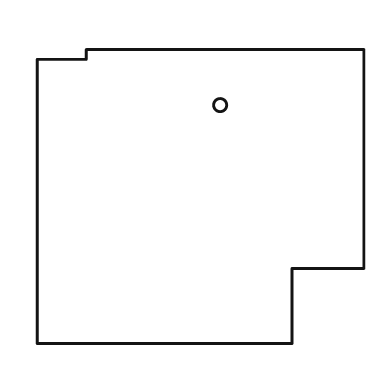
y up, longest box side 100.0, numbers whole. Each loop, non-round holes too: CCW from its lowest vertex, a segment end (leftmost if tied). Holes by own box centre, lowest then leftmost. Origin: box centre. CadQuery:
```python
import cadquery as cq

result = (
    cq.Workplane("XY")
    .moveTo(-50.0, -45.0)
    .lineTo(28.0, -45.0)
    .lineTo(28.0, -22.0)
    .lineTo(50.0, -22.0)
    .lineTo(50.0, 45.0)
    .lineTo(-35.0, 45.0)
    .lineTo(-35.0, 42.0)
    .lineTo(-50.0, 42.0)
    .close()
    .moveTo(6.0, 28.0)
    .circle(2.0)
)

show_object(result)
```